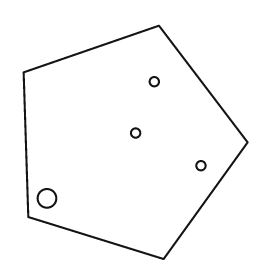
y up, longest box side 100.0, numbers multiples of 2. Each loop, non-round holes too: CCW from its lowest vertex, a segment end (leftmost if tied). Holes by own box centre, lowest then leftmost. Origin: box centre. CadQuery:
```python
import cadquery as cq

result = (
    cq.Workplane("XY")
    .moveTo(12.0, -50.0)
    .lineTo(48.0, 0.0)
    .lineTo(10.0, 50.0)
    .lineTo(-48.0, 30.0)
    .lineTo(-46.0, -32.0)
    .close()
    .moveTo(-38.0, -24.0)
    .circle(4.0)
    .moveTo(28.0, -10.0)
    .circle(2.0)
    .moveTo(0.0, 4.0)
    .circle(2.0)
    .moveTo(8.0, 26.0)
    .circle(2.0)
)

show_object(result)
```